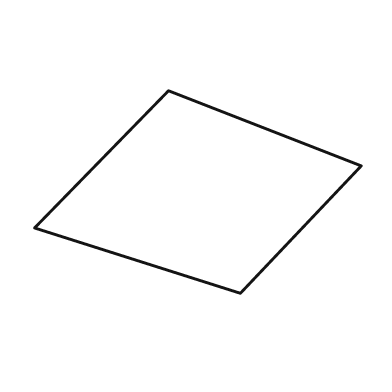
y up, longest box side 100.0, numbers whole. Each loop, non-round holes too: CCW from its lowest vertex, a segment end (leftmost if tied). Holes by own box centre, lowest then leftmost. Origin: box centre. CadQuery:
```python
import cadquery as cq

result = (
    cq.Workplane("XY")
    .moveTo(13.0, -31.0)
    .lineTo(50.0, 8.0)
    .lineTo(-9.0, 31.0)
    .lineTo(-50.0, -11.0)
    .close()
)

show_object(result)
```